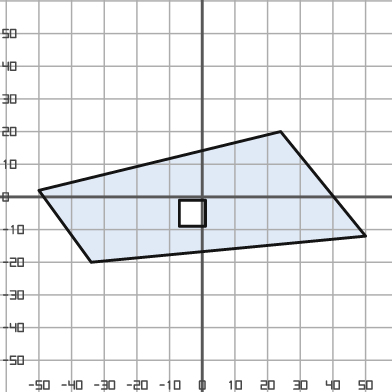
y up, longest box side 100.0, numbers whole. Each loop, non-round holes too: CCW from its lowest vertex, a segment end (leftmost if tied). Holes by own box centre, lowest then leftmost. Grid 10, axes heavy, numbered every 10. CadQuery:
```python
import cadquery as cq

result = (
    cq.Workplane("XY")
    .moveTo(-34.0, -20.0)
    .lineTo(50.0, -12.0)
    .lineTo(24.0, 20.0)
    .lineTo(-50.0, 2.0)
    .close()
    .moveTo(-7.0, -9.0)
    .lineTo(1.0, -9.0)
    .lineTo(1.0, -1.0)
    .lineTo(-7.0, -1.0)
    .close()
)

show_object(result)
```